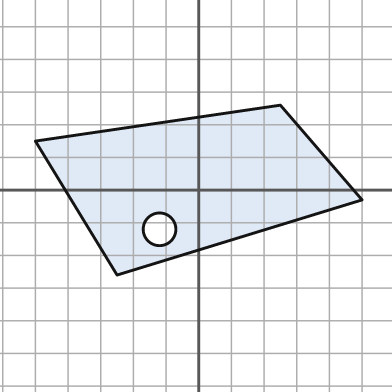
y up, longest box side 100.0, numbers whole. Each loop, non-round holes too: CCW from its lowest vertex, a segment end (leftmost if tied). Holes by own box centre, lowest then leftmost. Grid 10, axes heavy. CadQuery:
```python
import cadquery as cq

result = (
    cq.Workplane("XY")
    .moveTo(-25.0, -26.0)
    .lineTo(50.0, -3.0)
    .lineTo(25.0, 26.0)
    .lineTo(-50.0, 15.0)
    .close()
    .moveTo(-12.0, -12.0)
    .circle(5.0)
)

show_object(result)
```